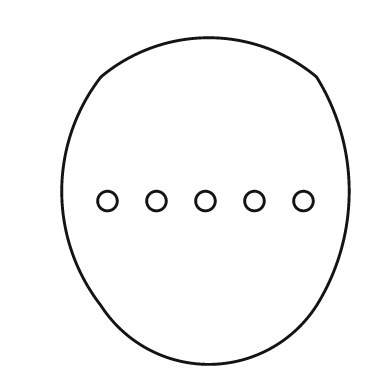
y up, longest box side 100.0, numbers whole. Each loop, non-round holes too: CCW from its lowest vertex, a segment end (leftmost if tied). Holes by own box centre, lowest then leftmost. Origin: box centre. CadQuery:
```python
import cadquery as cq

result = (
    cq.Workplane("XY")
    .moveTo(-32.0, -32.0)
    .threePointArc((1.0, -50.0), (34.0, -32.0))
    .threePointArc((44.0, 3.0), (34.0, 38.0))
    .threePointArc((1.0, 50.0), (-32.0, 38.0))
    .threePointArc((-44.0, 3.0), (-32.0, -32.0))
    .close()
    .moveTo(-30.0, 0.0)
    .circle(3.0)
    .moveTo(-15.0, 0.0)
    .circle(3.0)
    .moveTo(0.0, 0.0)
    .circle(3.0)
    .moveTo(15.0, 0.0)
    .circle(3.0)
    .moveTo(30.0, 0.0)
    .circle(3.0)
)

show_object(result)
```